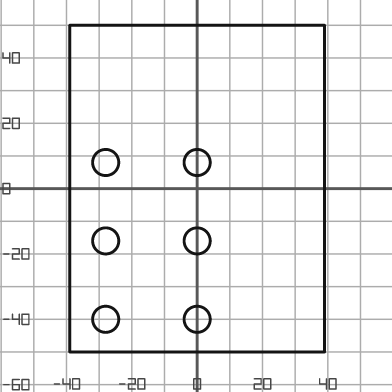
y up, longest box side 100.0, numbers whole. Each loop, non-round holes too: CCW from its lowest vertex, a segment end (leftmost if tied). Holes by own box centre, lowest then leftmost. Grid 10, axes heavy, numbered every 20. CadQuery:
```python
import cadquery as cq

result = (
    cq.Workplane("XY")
    .moveTo(-39.0, -50.0)
    .lineTo(39.0, -50.0)
    .lineTo(39.0, 50.0)
    .lineTo(-39.0, 50.0)
    .close()
    .moveTo(-28.0, -40.0)
    .circle(4.0)
    .moveTo(0.0, -40.0)
    .circle(4.0)
    .moveTo(-28.0, -16.0)
    .circle(4.0)
    .moveTo(0.0, -16.0)
    .circle(4.0)
    .moveTo(-28.0, 8.0)
    .circle(4.0)
    .moveTo(0.0, 8.0)
    .circle(4.0)
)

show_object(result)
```